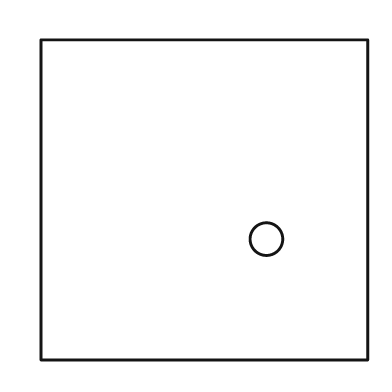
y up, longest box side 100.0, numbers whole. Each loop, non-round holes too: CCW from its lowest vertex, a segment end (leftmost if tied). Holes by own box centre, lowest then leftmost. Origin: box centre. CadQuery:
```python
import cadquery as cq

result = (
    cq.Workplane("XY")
    .moveTo(-50.0, -49.0)
    .lineTo(50.0, -49.0)
    .lineTo(50.0, 49.0)
    .lineTo(-50.0, 49.0)
    .close()
    .moveTo(19.0, -12.0)
    .circle(5.0)
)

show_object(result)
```